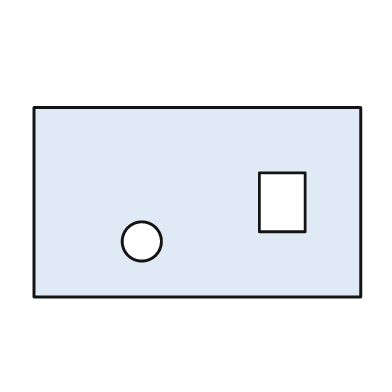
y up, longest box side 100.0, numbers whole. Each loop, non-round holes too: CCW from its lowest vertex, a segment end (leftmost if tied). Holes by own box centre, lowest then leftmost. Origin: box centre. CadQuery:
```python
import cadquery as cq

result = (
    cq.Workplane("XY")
    .moveTo(-50.0, -29.0)
    .lineTo(50.0, -29.0)
    .lineTo(50.0, 29.0)
    .lineTo(-50.0, 29.0)
    .close()
    .moveTo(-17.0, -12.0)
    .circle(6.0)
    .moveTo(19.0, -9.0)
    .lineTo(33.0, -9.0)
    .lineTo(33.0, 9.0)
    .lineTo(19.0, 9.0)
    .close()
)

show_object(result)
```